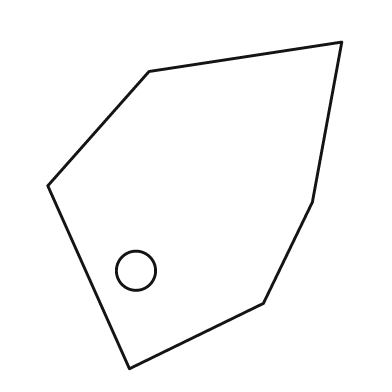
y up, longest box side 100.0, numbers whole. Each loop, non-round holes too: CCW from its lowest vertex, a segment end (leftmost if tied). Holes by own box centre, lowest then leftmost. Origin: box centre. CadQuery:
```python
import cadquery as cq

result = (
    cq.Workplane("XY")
    .moveTo(-20.0, -50.0)
    .lineTo(21.0, -30.0)
    .lineTo(36.0, 1.0)
    .lineTo(45.0, 50.0)
    .lineTo(-14.0, 41.0)
    .lineTo(-45.0, 6.0)
    .close()
    .moveTo(-18.0, -20.0)
    .circle(6.0)
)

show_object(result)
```